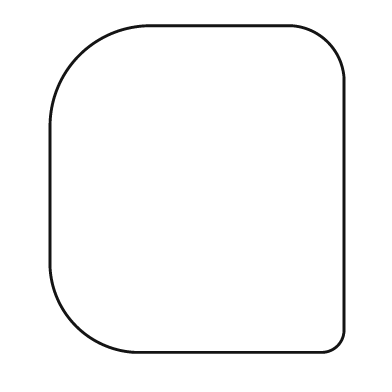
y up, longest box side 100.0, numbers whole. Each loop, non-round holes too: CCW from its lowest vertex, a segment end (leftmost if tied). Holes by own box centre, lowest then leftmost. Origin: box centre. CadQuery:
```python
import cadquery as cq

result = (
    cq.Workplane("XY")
    .moveTo(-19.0, -50.0)
    .lineTo(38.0, -50.0)
    .threePointArc((43.0, -48.0), (45.0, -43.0))
    .lineTo(45.0, 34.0)
    .threePointArc((40.0, 45.0), (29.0, 50.0))
    .lineTo(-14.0, 50.0)
    .threePointArc((-36.0, 41.0), (-45.0, 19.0))
    .lineTo(-45.0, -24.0)
    .threePointArc((-37.0, -42.0), (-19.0, -50.0))
    .close()
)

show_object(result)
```